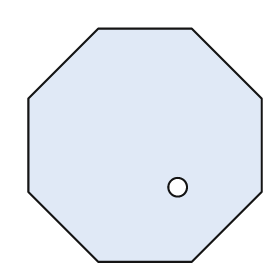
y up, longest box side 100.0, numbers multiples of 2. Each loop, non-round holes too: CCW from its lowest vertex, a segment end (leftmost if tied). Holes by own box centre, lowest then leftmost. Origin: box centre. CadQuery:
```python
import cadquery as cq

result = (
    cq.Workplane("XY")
    .moveTo(-20.0, -50.0)
    .lineTo(20.0, -50.0)
    .lineTo(50.0, -20.0)
    .lineTo(50.0, 20.0)
    .lineTo(20.0, 50.0)
    .lineTo(-20.0, 50.0)
    .lineTo(-50.0, 20.0)
    .lineTo(-50.0, -20.0)
    .close()
    .moveTo(14.0, -18.0)
    .circle(4.0)
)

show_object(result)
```